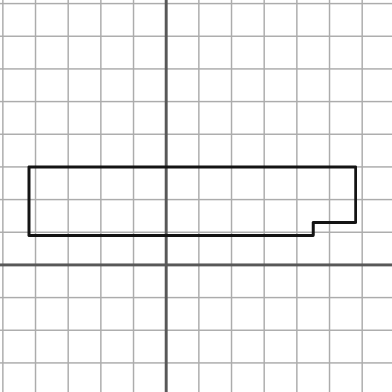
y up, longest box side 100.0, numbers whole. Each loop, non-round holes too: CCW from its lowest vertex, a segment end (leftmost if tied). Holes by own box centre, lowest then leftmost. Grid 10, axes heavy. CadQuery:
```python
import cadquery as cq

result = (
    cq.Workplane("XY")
    .moveTo(-42.0, 9.0)
    .lineTo(45.0, 9.0)
    .lineTo(45.0, 13.0)
    .lineTo(58.0, 13.0)
    .lineTo(58.0, 30.0)
    .lineTo(-42.0, 30.0)
    .close()
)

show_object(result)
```